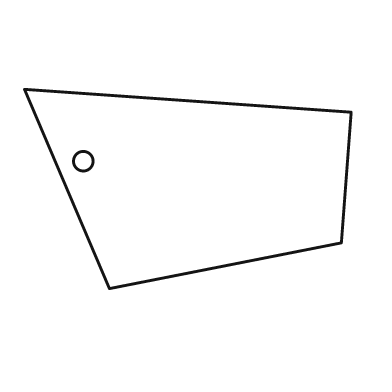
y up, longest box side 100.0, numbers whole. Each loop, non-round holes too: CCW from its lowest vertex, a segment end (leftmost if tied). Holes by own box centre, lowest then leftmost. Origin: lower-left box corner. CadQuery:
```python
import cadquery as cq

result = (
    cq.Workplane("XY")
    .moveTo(26.0, 0.0)
    .lineTo(97.0, 14.0)
    .lineTo(100.0, 54.0)
    .lineTo(0.0, 61.0)
    .close()
    .moveTo(18.0, 39.0)
    .circle(3.0)
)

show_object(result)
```